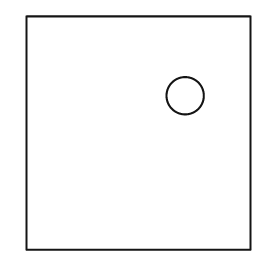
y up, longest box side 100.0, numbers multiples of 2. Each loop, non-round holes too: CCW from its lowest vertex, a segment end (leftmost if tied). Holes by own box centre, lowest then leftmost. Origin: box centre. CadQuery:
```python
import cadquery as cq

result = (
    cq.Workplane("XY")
    .moveTo(-48.0, -50.0)
    .lineTo(48.0, -50.0)
    .lineTo(48.0, 50.0)
    .lineTo(-48.0, 50.0)
    .close()
    .moveTo(20.0, 16.0)
    .circle(8.0)
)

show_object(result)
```